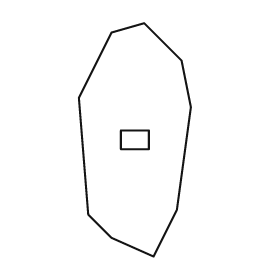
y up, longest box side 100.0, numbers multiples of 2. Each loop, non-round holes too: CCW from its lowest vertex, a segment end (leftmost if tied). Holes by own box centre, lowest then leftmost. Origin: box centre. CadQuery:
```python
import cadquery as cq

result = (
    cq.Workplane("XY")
    .moveTo(8.0, -50.0)
    .lineTo(18.0, -30.0)
    .lineTo(24.0, 14.0)
    .lineTo(20.0, 34.0)
    .lineTo(4.0, 50.0)
    .lineTo(-10.0, 46.0)
    .lineTo(-24.0, 18.0)
    .lineTo(-20.0, -32.0)
    .lineTo(-10.0, -42.0)
    .close()
    .moveTo(-6.0, -4.0)
    .lineTo(6.0, -4.0)
    .lineTo(6.0, 4.0)
    .lineTo(-6.0, 4.0)
    .close()
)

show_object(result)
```